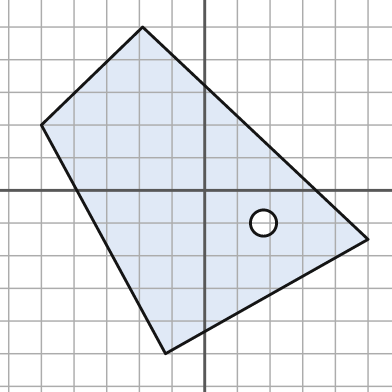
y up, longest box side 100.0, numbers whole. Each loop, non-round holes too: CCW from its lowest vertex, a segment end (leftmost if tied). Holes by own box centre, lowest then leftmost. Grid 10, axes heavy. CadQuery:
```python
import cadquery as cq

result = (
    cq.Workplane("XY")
    .moveTo(-12.0, -50.0)
    .lineTo(50.0, -15.0)
    .lineTo(-19.0, 50.0)
    .lineTo(-50.0, 20.0)
    .close()
    .moveTo(18.0, -10.0)
    .circle(4.0)
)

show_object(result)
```